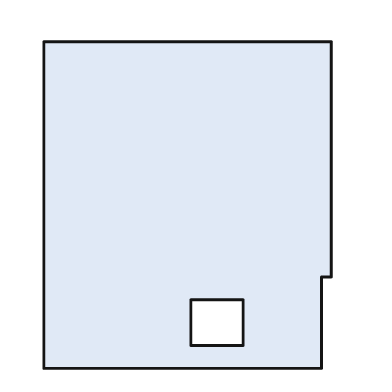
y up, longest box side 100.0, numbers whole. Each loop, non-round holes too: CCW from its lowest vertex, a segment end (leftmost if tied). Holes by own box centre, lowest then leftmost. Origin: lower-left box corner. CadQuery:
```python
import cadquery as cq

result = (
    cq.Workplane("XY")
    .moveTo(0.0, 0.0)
    .lineTo(85.0, 0.0)
    .lineTo(85.0, 28.0)
    .lineTo(88.0, 28.0)
    .lineTo(88.0, 100.0)
    .lineTo(0.0, 100.0)
    .close()
    .moveTo(45.0, 7.0)
    .lineTo(61.0, 7.0)
    .lineTo(61.0, 21.0)
    .lineTo(45.0, 21.0)
    .close()
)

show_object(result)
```